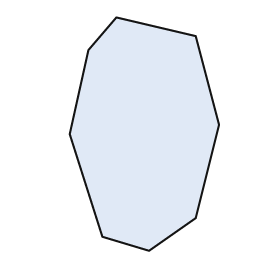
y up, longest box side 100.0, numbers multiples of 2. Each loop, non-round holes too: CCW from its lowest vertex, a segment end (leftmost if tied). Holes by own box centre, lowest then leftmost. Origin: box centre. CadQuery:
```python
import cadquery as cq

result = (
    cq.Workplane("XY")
    .moveTo(2.0, -50.0)
    .lineTo(22.0, -36.0)
    .lineTo(32.0, 4.0)
    .lineTo(22.0, 42.0)
    .lineTo(-12.0, 50.0)
    .lineTo(-24.0, 36.0)
    .lineTo(-32.0, 0.0)
    .lineTo(-18.0, -44.0)
    .close()
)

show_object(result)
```